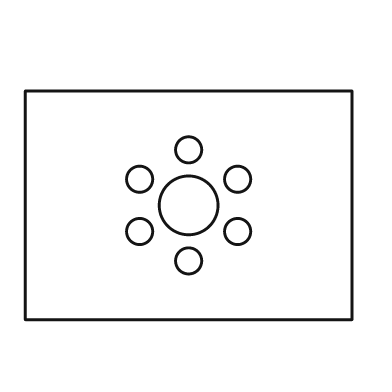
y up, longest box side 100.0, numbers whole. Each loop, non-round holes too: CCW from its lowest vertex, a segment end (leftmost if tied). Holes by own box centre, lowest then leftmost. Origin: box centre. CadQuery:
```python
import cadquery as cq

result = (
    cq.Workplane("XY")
    .moveTo(-50.0, -35.0)
    .lineTo(50.0, -35.0)
    .lineTo(50.0, 35.0)
    .lineTo(-50.0, 35.0)
    .close()
    .moveTo(0.0, -17.0)
    .circle(4.0)
    .moveTo(-15.0, -8.0)
    .circle(4.0)
    .moveTo(15.0, -8.0)
    .circle(4.0)
    .moveTo(0.0, 0.0)
    .circle(9.0)
    .moveTo(-15.0, 8.0)
    .circle(4.0)
    .moveTo(15.0, 8.0)
    .circle(4.0)
    .moveTo(0.0, 17.0)
    .circle(4.0)
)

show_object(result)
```